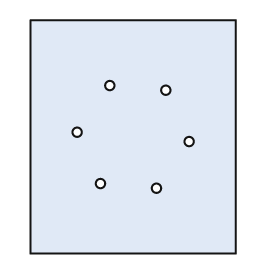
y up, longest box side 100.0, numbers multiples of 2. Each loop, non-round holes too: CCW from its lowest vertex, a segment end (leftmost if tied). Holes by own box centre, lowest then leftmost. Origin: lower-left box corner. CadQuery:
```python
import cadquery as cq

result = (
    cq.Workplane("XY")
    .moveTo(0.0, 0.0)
    .lineTo(88.0, 0.0)
    .lineTo(88.0, 100.0)
    .lineTo(0.0, 100.0)
    .close()
    .moveTo(54.0, 28.0)
    .circle(2.0)
    .moveTo(30.0, 30.0)
    .circle(2.0)
    .moveTo(68.0, 48.0)
    .circle(2.0)
    .moveTo(20.0, 52.0)
    .circle(2.0)
    .moveTo(58.0, 70.0)
    .circle(2.0)
    .moveTo(34.0, 72.0)
    .circle(2.0)
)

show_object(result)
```